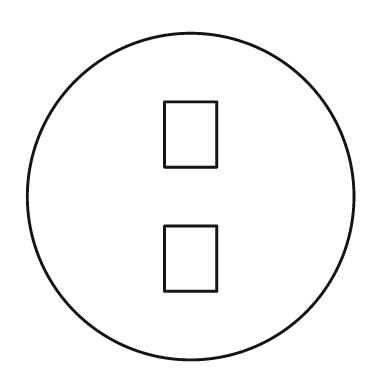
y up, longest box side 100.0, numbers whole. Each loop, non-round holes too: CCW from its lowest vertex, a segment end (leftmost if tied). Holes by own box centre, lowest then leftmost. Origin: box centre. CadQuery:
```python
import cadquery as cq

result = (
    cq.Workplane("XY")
    .moveTo(0.0, 0.0)
    .circle(50.0)
    .moveTo(-8.0, -29.0)
    .lineTo(8.0, -29.0)
    .lineTo(8.0, -9.0)
    .lineTo(-8.0, -9.0)
    .close()
    .moveTo(-8.0, 9.0)
    .lineTo(8.0, 9.0)
    .lineTo(8.0, 29.0)
    .lineTo(-8.0, 29.0)
    .close()
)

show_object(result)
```